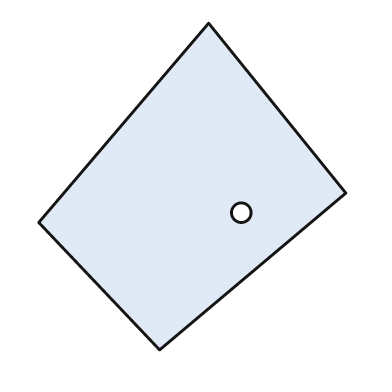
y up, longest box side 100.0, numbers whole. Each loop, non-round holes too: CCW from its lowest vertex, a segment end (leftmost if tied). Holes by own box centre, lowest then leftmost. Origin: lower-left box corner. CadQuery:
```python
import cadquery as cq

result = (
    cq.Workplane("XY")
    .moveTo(37.0, 0.0)
    .lineTo(94.0, 48.0)
    .lineTo(52.0, 100.0)
    .lineTo(0.0, 39.0)
    .close()
    .moveTo(62.0, 42.0)
    .circle(3.0)
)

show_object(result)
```